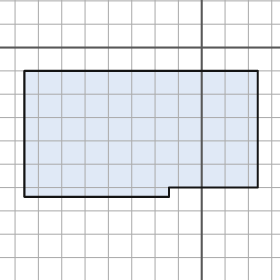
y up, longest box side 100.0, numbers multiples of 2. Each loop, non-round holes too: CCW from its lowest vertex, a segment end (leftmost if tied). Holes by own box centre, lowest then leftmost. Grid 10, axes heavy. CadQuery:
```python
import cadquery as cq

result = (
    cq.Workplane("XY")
    .moveTo(-76.0, -64.0)
    .lineTo(-14.0, -64.0)
    .lineTo(-14.0, -60.0)
    .lineTo(24.0, -60.0)
    .lineTo(24.0, -10.0)
    .lineTo(-76.0, -10.0)
    .close()
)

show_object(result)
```